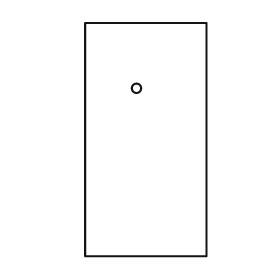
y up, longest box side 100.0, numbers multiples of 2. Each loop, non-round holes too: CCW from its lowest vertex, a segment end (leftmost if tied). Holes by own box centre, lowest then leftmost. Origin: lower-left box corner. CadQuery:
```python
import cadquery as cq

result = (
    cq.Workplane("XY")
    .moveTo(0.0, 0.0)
    .lineTo(52.0, 0.0)
    .lineTo(52.0, 100.0)
    .lineTo(0.0, 100.0)
    .close()
    .moveTo(22.0, 72.0)
    .circle(2.0)
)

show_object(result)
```